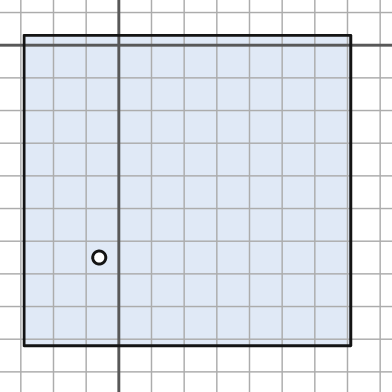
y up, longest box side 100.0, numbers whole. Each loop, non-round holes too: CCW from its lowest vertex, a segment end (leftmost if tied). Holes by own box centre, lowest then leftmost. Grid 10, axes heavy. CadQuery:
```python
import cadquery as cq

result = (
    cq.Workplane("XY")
    .moveTo(-29.0, -92.0)
    .lineTo(71.0, -92.0)
    .lineTo(71.0, 3.0)
    .lineTo(-29.0, 3.0)
    .close()
    .moveTo(-6.0, -65.0)
    .circle(2.0)
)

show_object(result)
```